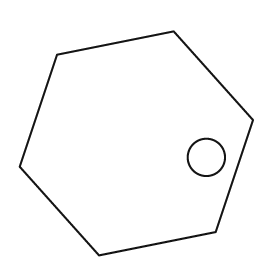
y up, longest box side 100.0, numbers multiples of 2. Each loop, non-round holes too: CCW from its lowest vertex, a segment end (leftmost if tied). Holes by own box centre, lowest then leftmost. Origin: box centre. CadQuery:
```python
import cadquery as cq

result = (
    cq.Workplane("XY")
    .moveTo(-16.0, -48.0)
    .lineTo(34.0, -38.0)
    .lineTo(50.0, 10.0)
    .lineTo(16.0, 48.0)
    .lineTo(-34.0, 38.0)
    .lineTo(-50.0, -10.0)
    .close()
    .moveTo(30.0, -6.0)
    .circle(8.0)
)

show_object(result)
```